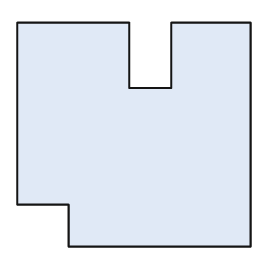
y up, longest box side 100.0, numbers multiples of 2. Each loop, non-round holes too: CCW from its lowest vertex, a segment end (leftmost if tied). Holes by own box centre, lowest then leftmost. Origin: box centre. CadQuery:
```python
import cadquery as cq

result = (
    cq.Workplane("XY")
    .moveTo(-28.0, -48.0)
    .lineTo(50.0, -48.0)
    .lineTo(50.0, 48.0)
    .lineTo(16.0, 48.0)
    .lineTo(16.0, 20.0)
    .lineTo(-2.0, 20.0)
    .lineTo(-2.0, 48.0)
    .lineTo(-50.0, 48.0)
    .lineTo(-50.0, -30.0)
    .lineTo(-28.0, -30.0)
    .close()
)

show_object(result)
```